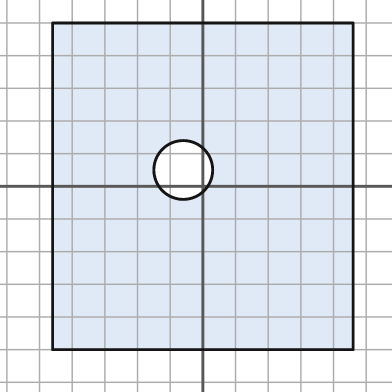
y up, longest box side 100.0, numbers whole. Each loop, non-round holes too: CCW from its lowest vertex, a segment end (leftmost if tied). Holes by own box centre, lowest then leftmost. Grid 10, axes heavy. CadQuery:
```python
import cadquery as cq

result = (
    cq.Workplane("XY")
    .moveTo(-46.0, -50.0)
    .lineTo(46.0, -50.0)
    .lineTo(46.0, 50.0)
    .lineTo(-46.0, 50.0)
    .close()
    .moveTo(-6.0, 5.0)
    .circle(9.0)
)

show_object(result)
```